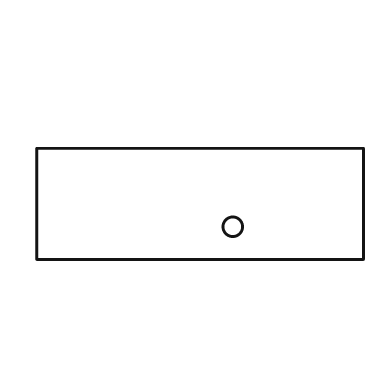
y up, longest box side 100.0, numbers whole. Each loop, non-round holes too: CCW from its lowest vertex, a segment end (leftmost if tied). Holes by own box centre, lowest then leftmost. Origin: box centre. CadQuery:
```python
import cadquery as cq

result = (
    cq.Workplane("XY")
    .moveTo(-50.0, -17.0)
    .lineTo(50.0, -17.0)
    .lineTo(50.0, 17.0)
    .lineTo(-50.0, 17.0)
    .close()
    .moveTo(10.0, -7.0)
    .circle(3.0)
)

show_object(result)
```